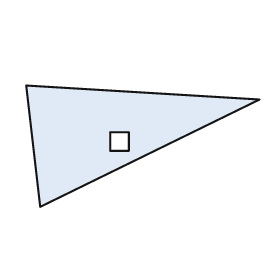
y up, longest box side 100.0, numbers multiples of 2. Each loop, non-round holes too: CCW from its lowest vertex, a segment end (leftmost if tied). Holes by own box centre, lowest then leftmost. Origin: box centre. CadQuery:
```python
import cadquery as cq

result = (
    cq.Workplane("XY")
    .moveTo(-44.0, -26.0)
    .lineTo(50.0, 20.0)
    .lineTo(-50.0, 26.0)
    .close()
    .moveTo(-14.0, -2.0)
    .lineTo(-6.0, -2.0)
    .lineTo(-6.0, 6.0)
    .lineTo(-14.0, 6.0)
    .close()
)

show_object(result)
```